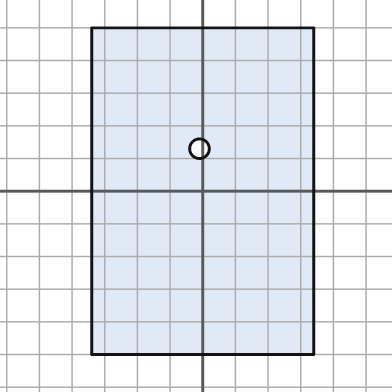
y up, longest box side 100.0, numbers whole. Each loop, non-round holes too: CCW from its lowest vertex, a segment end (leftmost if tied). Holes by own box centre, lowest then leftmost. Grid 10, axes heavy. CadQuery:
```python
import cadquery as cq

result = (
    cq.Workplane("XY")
    .moveTo(-34.0, -50.0)
    .lineTo(34.0, -50.0)
    .lineTo(34.0, 50.0)
    .lineTo(-34.0, 50.0)
    .close()
    .moveTo(-1.0, 13.0)
    .circle(3.0)
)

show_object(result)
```